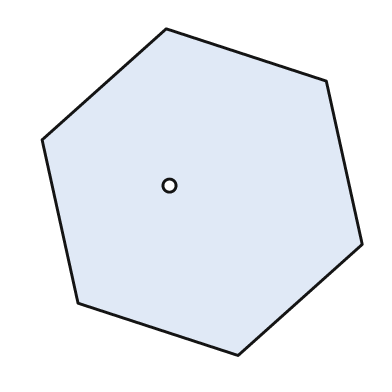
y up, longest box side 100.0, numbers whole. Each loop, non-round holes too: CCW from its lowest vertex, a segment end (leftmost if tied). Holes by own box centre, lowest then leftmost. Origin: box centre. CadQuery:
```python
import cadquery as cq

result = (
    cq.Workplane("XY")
    .moveTo(11.0, -50.0)
    .lineTo(49.0, -16.0)
    .lineTo(38.0, 34.0)
    .lineTo(-11.0, 50.0)
    .lineTo(-49.0, 16.0)
    .lineTo(-38.0, -34.0)
    .close()
    .moveTo(-10.0, 2.0)
    .circle(2.0)
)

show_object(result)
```